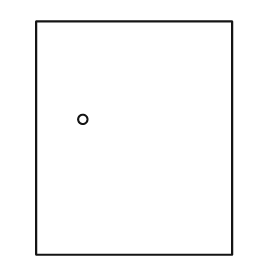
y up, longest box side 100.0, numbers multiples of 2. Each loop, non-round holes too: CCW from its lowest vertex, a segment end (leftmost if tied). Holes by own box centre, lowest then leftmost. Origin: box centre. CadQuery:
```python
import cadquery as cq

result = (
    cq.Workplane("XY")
    .moveTo(-42.0, -50.0)
    .lineTo(42.0, -50.0)
    .lineTo(42.0, 50.0)
    .lineTo(-42.0, 50.0)
    .close()
    .moveTo(-22.0, 8.0)
    .circle(2.0)
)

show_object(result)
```